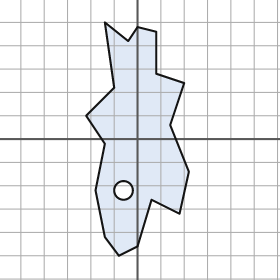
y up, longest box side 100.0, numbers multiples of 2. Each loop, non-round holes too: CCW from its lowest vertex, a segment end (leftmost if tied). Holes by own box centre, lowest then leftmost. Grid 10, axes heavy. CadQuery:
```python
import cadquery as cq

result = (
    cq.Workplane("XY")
    .moveTo(-8.0, -50.0)
    .lineTo(0.0, -46.0)
    .lineTo(6.0, -26.0)
    .lineTo(18.0, -32.0)
    .lineTo(22.0, -14.0)
    .lineTo(14.0, 6.0)
    .lineTo(20.0, 24.0)
    .lineTo(8.0, 28.0)
    .lineTo(8.0, 46.0)
    .lineTo(0.0, 48.0)
    .lineTo(-4.0, 42.0)
    .lineTo(-14.0, 50.0)
    .lineTo(-10.0, 22.0)
    .lineTo(-22.0, 10.0)
    .lineTo(-14.0, -2.0)
    .lineTo(-18.0, -22.0)
    .lineTo(-14.0, -42.0)
    .close()
    .moveTo(-6.0, -22.0)
    .circle(4.0)
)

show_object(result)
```